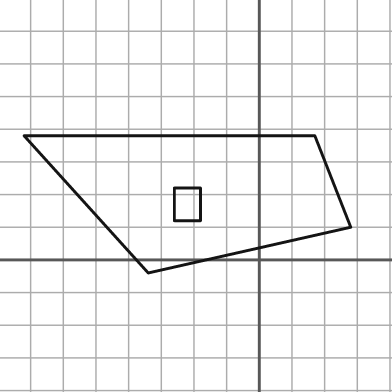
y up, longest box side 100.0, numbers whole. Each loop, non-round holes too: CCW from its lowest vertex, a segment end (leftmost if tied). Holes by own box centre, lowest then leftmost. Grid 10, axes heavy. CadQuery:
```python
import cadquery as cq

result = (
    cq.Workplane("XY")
    .moveTo(-34.0, -4.0)
    .lineTo(28.0, 10.0)
    .lineTo(17.0, 38.0)
    .lineTo(-72.0, 38.0)
    .close()
    .moveTo(-26.0, 12.0)
    .lineTo(-18.0, 12.0)
    .lineTo(-18.0, 22.0)
    .lineTo(-26.0, 22.0)
    .close()
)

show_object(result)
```